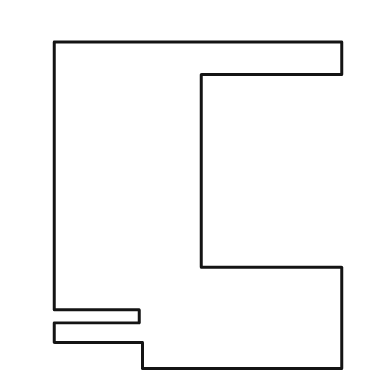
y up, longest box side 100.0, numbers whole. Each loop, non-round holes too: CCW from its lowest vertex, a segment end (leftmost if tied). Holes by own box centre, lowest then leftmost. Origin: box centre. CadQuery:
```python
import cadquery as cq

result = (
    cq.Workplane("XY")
    .moveTo(-17.0, -50.0)
    .lineTo(44.0, -50.0)
    .lineTo(44.0, -19.0)
    .lineTo(1.0, -19.0)
    .lineTo(1.0, 40.0)
    .lineTo(44.0, 40.0)
    .lineTo(44.0, 50.0)
    .lineTo(-44.0, 50.0)
    .lineTo(-44.0, -32.0)
    .lineTo(-18.0, -32.0)
    .lineTo(-18.0, -36.0)
    .lineTo(-44.0, -36.0)
    .lineTo(-44.0, -42.0)
    .lineTo(-17.0, -42.0)
    .close()
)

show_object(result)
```